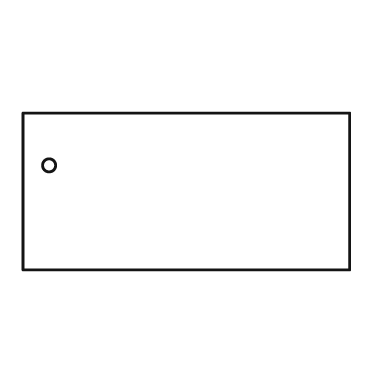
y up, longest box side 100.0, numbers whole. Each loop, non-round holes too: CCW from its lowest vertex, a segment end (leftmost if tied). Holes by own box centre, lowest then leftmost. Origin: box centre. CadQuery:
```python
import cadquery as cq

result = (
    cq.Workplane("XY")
    .moveTo(-50.0, -24.0)
    .lineTo(50.0, -24.0)
    .lineTo(50.0, 24.0)
    .lineTo(-50.0, 24.0)
    .close()
    .moveTo(-42.0, 8.0)
    .circle(2.0)
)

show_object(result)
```